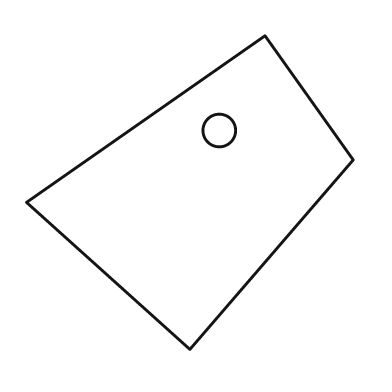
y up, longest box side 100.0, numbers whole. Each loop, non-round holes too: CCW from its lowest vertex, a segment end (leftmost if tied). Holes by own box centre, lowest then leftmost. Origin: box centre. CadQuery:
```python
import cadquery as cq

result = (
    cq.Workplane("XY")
    .moveTo(0.0, -48.0)
    .lineTo(50.0, 10.0)
    .lineTo(23.0, 48.0)
    .lineTo(-50.0, -3.0)
    .close()
    .moveTo(9.0, 19.0)
    .circle(5.0)
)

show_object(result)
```